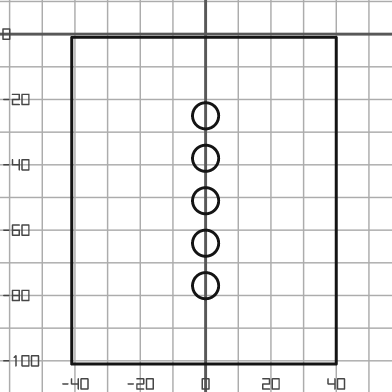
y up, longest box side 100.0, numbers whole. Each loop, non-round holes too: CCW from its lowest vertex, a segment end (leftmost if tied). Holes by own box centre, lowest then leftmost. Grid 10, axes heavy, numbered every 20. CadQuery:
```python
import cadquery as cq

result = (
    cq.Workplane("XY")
    .moveTo(-41.0, -101.0)
    .lineTo(40.0, -101.0)
    .lineTo(40.0, -1.0)
    .lineTo(-41.0, -1.0)
    .close()
    .moveTo(0.0, -77.0)
    .circle(4.0)
    .moveTo(0.0, -64.0)
    .circle(4.0)
    .moveTo(0.0, -51.0)
    .circle(4.0)
    .moveTo(0.0, -38.0)
    .circle(4.0)
    .moveTo(0.0, -25.0)
    .circle(4.0)
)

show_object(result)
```